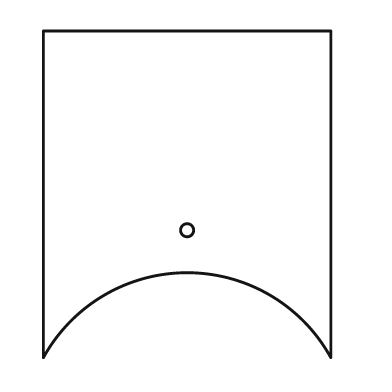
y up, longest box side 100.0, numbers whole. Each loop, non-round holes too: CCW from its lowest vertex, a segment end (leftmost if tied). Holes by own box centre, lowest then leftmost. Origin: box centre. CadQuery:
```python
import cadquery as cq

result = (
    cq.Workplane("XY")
    .moveTo(-44.0, -50.0)
    .threePointArc((0.0, -24.0), (44.0, -50.0))
    .lineTo(44.0, 50.0)
    .lineTo(-44.0, 50.0)
    .close()
    .moveTo(0.0, -11.0)
    .circle(2.0)
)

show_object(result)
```